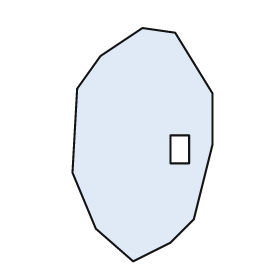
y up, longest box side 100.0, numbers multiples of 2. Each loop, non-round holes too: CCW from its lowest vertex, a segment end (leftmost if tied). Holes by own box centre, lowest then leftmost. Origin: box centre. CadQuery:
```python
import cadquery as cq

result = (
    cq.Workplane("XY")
    .moveTo(-4.0, -50.0)
    .lineTo(12.0, -42.0)
    .lineTo(22.0, -32.0)
    .lineTo(30.0, 0.0)
    .lineTo(30.0, 22.0)
    .lineTo(14.0, 48.0)
    .lineTo(0.0, 50.0)
    .lineTo(-18.0, 38.0)
    .lineTo(-28.0, 24.0)
    .lineTo(-30.0, -12.0)
    .lineTo(-20.0, -36.0)
    .close()
    .moveTo(12.0, -8.0)
    .lineTo(20.0, -8.0)
    .lineTo(20.0, 4.0)
    .lineTo(12.0, 4.0)
    .close()
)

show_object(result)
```